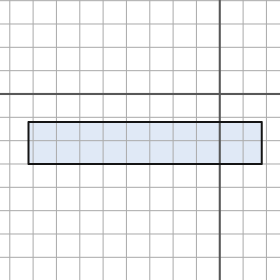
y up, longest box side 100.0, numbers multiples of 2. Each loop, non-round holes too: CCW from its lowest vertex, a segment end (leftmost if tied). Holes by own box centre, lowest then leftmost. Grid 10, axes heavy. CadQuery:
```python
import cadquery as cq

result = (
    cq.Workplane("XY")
    .moveTo(-82.0, -30.0)
    .lineTo(18.0, -30.0)
    .lineTo(18.0, -12.0)
    .lineTo(-82.0, -12.0)
    .close()
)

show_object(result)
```